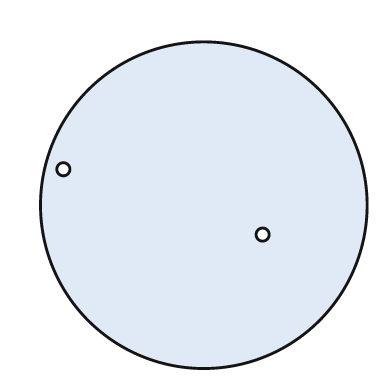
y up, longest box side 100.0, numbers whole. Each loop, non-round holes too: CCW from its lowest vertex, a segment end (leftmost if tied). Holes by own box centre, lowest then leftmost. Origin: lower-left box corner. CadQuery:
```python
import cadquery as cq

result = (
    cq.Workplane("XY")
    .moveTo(50.0, 50.0)
    .circle(50.0)
    .moveTo(68.0, 41.0)
    .circle(2.0)
    .moveTo(7.0, 61.0)
    .circle(2.0)
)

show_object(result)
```